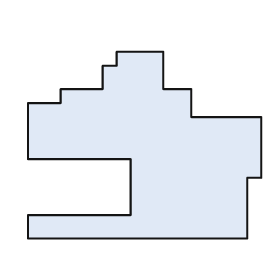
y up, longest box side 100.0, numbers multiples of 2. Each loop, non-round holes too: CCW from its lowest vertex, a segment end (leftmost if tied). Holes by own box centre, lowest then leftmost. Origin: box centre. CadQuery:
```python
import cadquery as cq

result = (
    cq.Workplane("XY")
    .moveTo(-50.0, -40.0)
    .lineTo(44.0, -40.0)
    .lineTo(44.0, -14.0)
    .lineTo(50.0, -14.0)
    .lineTo(50.0, 12.0)
    .lineTo(20.0, 12.0)
    .lineTo(20.0, 24.0)
    .lineTo(8.0, 24.0)
    .lineTo(8.0, 40.0)
    .lineTo(-12.0, 40.0)
    .lineTo(-12.0, 34.0)
    .lineTo(-18.0, 34.0)
    .lineTo(-18.0, 24.0)
    .lineTo(-36.0, 24.0)
    .lineTo(-36.0, 18.0)
    .lineTo(-50.0, 18.0)
    .lineTo(-50.0, -6.0)
    .lineTo(-6.0, -6.0)
    .lineTo(-6.0, -30.0)
    .lineTo(-50.0, -30.0)
    .close()
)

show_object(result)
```